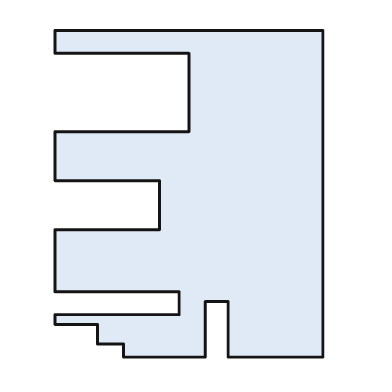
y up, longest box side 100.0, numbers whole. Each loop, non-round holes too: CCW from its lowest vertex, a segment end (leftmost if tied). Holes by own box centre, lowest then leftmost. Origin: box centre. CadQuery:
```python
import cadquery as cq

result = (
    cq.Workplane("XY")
    .moveTo(-20.0, -50.0)
    .lineTo(5.0, -50.0)
    .lineTo(5.0, -33.0)
    .lineTo(12.0, -33.0)
    .lineTo(12.0, -50.0)
    .lineTo(41.0, -50.0)
    .lineTo(41.0, 50.0)
    .lineTo(-41.0, 50.0)
    .lineTo(-41.0, 43.0)
    .lineTo(0.0, 43.0)
    .lineTo(0.0, 19.0)
    .lineTo(-41.0, 19.0)
    .lineTo(-41.0, 4.0)
    .lineTo(-9.0, 4.0)
    .lineTo(-9.0, -11.0)
    .lineTo(-41.0, -11.0)
    .lineTo(-41.0, -30.0)
    .lineTo(-3.0, -30.0)
    .lineTo(-3.0, -37.0)
    .lineTo(-41.0, -37.0)
    .lineTo(-41.0, -40.0)
    .lineTo(-28.0, -40.0)
    .lineTo(-28.0, -46.0)
    .lineTo(-20.0, -46.0)
    .close()
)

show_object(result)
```